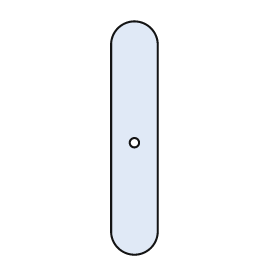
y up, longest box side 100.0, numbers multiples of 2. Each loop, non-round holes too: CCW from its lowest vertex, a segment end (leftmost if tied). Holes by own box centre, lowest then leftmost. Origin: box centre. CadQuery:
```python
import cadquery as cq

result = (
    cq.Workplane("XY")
    .moveTo(-10.0, -40.0)
    .threePointArc((0.0, -50.0), (10.0, -40.0))
    .lineTo(10.0, 40.0)
    .threePointArc((0.0, 50.0), (-10.0, 40.0))
    .close()
    .moveTo(0.0, -2.0)
    .circle(2.0)
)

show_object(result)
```